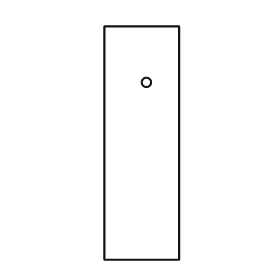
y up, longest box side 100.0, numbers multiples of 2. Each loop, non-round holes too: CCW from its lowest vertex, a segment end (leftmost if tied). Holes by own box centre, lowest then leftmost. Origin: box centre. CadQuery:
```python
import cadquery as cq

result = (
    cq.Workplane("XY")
    .moveTo(-16.0, -50.0)
    .lineTo(16.0, -50.0)
    .lineTo(16.0, 50.0)
    .lineTo(-16.0, 50.0)
    .close()
    .moveTo(2.0, 26.0)
    .circle(2.0)
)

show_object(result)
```